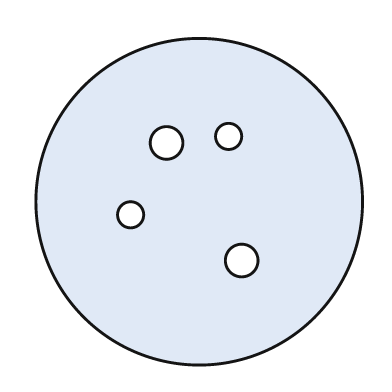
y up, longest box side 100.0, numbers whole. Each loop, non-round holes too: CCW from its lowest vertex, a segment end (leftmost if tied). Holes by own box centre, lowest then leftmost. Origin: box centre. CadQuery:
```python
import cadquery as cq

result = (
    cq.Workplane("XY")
    .moveTo(0.0, 0.0)
    .circle(50.0)
    .moveTo(13.0, -18.0)
    .circle(5.0)
    .moveTo(-21.0, -4.0)
    .circle(4.0)
    .moveTo(-10.0, 18.0)
    .circle(5.0)
    .moveTo(9.0, 20.0)
    .circle(4.0)
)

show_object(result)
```